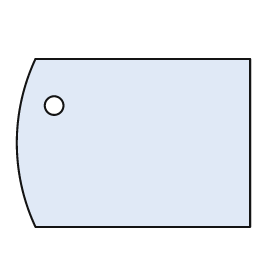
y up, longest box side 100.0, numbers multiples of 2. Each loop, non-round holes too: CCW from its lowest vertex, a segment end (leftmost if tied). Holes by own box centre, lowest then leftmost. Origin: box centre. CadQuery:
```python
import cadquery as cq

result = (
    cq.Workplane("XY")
    .moveTo(-42.0, -36.0)
    .lineTo(50.0, -36.0)
    .lineTo(50.0, 36.0)
    .lineTo(-42.0, 36.0)
    .threePointArc((-50.0, 0.0), (-42.0, -36.0))
    .close()
    .moveTo(-34.0, 16.0)
    .circle(4.0)
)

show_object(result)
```